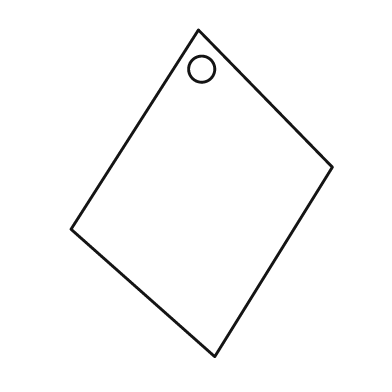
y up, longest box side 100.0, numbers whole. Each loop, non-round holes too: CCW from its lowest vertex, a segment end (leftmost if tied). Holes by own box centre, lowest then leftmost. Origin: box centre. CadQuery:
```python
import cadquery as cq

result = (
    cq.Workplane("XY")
    .moveTo(4.0, -50.0)
    .lineTo(40.0, 8.0)
    .lineTo(-1.0, 50.0)
    .lineTo(-40.0, -11.0)
    .close()
    .moveTo(0.0, 38.0)
    .circle(4.0)
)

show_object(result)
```